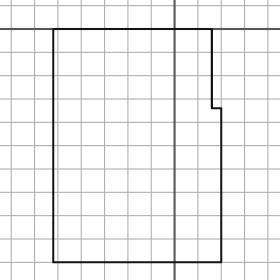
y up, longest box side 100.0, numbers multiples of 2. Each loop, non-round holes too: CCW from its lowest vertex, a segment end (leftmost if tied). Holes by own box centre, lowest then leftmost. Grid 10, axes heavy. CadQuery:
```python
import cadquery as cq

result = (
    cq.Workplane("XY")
    .moveTo(-52.0, -100.0)
    .lineTo(20.0, -100.0)
    .lineTo(20.0, -34.0)
    .lineTo(16.0, -34.0)
    .lineTo(16.0, 0.0)
    .lineTo(-52.0, 0.0)
    .close()
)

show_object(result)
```